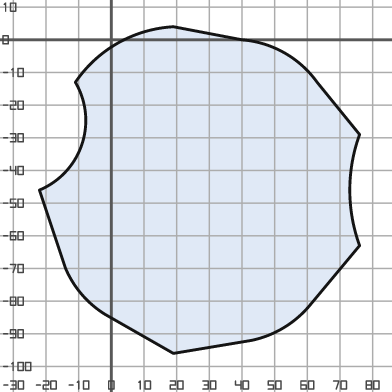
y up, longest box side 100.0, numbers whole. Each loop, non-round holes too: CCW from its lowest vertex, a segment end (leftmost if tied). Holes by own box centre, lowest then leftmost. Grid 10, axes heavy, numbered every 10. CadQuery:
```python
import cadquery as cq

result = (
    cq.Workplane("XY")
    .moveTo(19.0, -96.0)
    .lineTo(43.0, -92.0)
    .threePointArc((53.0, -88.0), (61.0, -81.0))
    .lineTo(76.0, -63.0)
    .threePointArc((73.0, -46.0), (76.0, -29.0))
    .lineTo(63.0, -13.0)
    .threePointArc((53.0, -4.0), (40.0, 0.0))
    .lineTo(19.0, 4.0)
    .threePointArc((2.0, -1.0), (-11.0, -13.0))
    .threePointArc((-9.0, -32.0), (-22.0, -46.0))
    .lineTo(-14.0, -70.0)
    .threePointArc((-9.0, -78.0), (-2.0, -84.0))
    .close()
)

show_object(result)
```